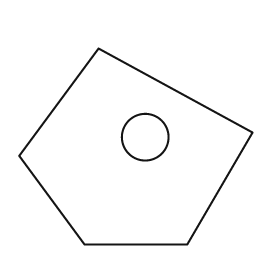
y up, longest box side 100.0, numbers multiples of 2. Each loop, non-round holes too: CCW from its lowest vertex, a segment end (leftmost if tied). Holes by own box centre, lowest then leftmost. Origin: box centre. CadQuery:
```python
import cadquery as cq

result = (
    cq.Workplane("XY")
    .moveTo(-22.0, -42.0)
    .lineTo(22.0, -42.0)
    .lineTo(50.0, 6.0)
    .lineTo(-16.0, 42.0)
    .lineTo(-50.0, -4.0)
    .close()
    .moveTo(4.0, 4.0)
    .circle(10.0)
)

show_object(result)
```